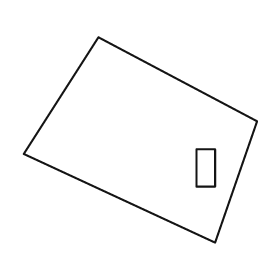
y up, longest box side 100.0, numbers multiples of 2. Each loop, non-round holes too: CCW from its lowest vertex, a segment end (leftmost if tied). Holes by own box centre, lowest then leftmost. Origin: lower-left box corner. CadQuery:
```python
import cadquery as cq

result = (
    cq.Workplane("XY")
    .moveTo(82.0, 0.0)
    .lineTo(100.0, 52.0)
    .lineTo(32.0, 88.0)
    .lineTo(0.0, 38.0)
    .close()
    .moveTo(74.0, 24.0)
    .lineTo(82.0, 24.0)
    .lineTo(82.0, 40.0)
    .lineTo(74.0, 40.0)
    .close()
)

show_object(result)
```